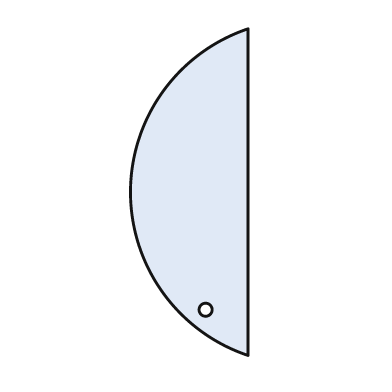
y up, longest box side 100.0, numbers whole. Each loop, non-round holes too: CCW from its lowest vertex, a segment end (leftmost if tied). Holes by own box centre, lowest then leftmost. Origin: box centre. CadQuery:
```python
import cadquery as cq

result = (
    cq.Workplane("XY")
    .moveTo(18.0, -50.0)
    .lineTo(18.0, 50.0)
    .threePointArc((-18.0, 0.0), (18.0, -50.0))
    .close()
    .moveTo(5.0, -36.0)
    .circle(2.0)
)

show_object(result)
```